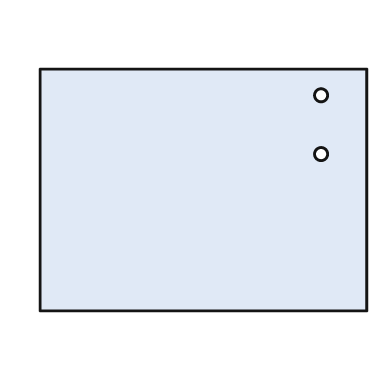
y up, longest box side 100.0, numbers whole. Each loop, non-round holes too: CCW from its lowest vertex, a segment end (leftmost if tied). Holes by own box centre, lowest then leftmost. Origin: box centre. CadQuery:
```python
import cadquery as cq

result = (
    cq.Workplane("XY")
    .moveTo(-50.0, -37.0)
    .lineTo(50.0, -37.0)
    .lineTo(50.0, 37.0)
    .lineTo(-50.0, 37.0)
    .close()
    .moveTo(36.0, 11.0)
    .circle(2.0)
    .moveTo(36.0, 29.0)
    .circle(2.0)
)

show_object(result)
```